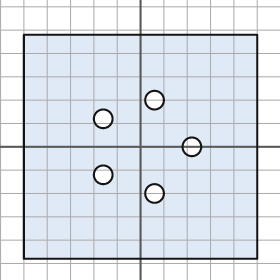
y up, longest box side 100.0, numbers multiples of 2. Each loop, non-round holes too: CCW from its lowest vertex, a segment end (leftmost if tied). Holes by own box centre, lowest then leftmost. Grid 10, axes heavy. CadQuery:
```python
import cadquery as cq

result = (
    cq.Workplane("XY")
    .moveTo(-50.0, -48.0)
    .lineTo(50.0, -48.0)
    .lineTo(50.0, 48.0)
    .lineTo(-50.0, 48.0)
    .close()
    .moveTo(6.0, -20.0)
    .circle(4.0)
    .moveTo(-16.0, -12.0)
    .circle(4.0)
    .moveTo(22.0, 0.0)
    .circle(4.0)
    .moveTo(-16.0, 12.0)
    .circle(4.0)
    .moveTo(6.0, 20.0)
    .circle(4.0)
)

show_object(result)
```